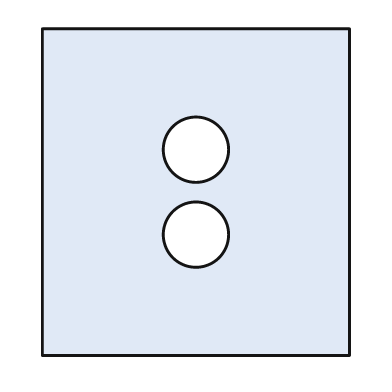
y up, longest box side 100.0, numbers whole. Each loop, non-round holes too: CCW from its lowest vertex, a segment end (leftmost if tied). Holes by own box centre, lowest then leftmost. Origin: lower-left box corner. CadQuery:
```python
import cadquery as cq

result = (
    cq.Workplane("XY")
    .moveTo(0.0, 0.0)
    .lineTo(94.0, 0.0)
    .lineTo(94.0, 100.0)
    .lineTo(0.0, 100.0)
    .close()
    .moveTo(47.0, 37.0)
    .circle(10.0)
    .moveTo(47.0, 63.0)
    .circle(10.0)
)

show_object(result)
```